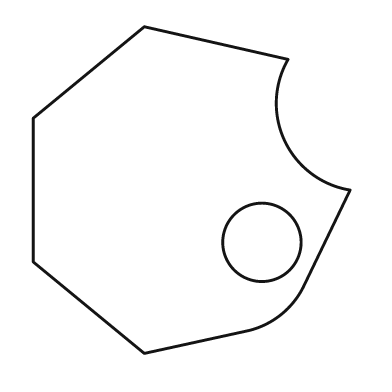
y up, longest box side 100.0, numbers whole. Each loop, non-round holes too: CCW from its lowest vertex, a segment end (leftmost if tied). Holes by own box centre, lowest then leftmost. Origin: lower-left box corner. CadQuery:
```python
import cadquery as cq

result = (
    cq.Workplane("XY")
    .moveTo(34.0, 0.0)
    .lineTo(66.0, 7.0)
    .threePointArc((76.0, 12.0), (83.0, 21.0))
    .lineTo(97.0, 50.0)
    .threePointArc((77.0, 65.0), (78.0, 90.0))
    .lineTo(34.0, 100.0)
    .lineTo(0.0, 72.0)
    .lineTo(0.0, 28.0)
    .close()
    .moveTo(70.0, 34.0)
    .circle(12.0)
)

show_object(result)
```